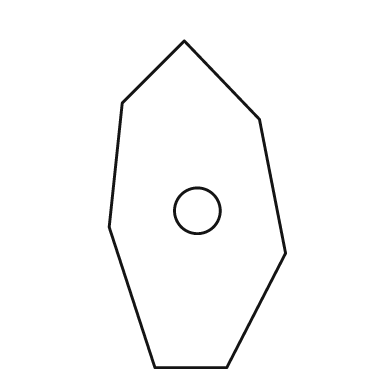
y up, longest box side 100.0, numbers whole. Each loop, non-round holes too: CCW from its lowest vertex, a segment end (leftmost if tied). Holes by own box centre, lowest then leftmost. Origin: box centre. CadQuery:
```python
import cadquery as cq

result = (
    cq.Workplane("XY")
    .moveTo(-13.0, -50.0)
    .lineTo(9.0, -50.0)
    .lineTo(27.0, -15.0)
    .lineTo(19.0, 26.0)
    .lineTo(-4.0, 50.0)
    .lineTo(-23.0, 31.0)
    .lineTo(-27.0, -7.0)
    .close()
    .moveTo(0.0, -2.0)
    .circle(7.0)
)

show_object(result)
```